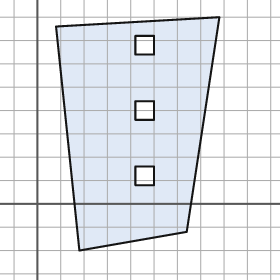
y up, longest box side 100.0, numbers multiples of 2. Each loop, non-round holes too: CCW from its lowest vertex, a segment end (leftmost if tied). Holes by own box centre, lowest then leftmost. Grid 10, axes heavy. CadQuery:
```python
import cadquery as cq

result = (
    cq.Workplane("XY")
    .moveTo(18.0, -20.0)
    .lineTo(64.0, -12.0)
    .lineTo(78.0, 80.0)
    .lineTo(8.0, 76.0)
    .close()
    .moveTo(42.0, 8.0)
    .lineTo(50.0, 8.0)
    .lineTo(50.0, 16.0)
    .lineTo(42.0, 16.0)
    .close()
    .moveTo(42.0, 36.0)
    .lineTo(50.0, 36.0)
    .lineTo(50.0, 44.0)
    .lineTo(42.0, 44.0)
    .close()
    .moveTo(42.0, 64.0)
    .lineTo(50.0, 64.0)
    .lineTo(50.0, 72.0)
    .lineTo(42.0, 72.0)
    .close()
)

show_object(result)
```